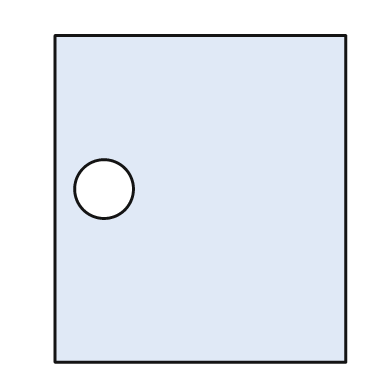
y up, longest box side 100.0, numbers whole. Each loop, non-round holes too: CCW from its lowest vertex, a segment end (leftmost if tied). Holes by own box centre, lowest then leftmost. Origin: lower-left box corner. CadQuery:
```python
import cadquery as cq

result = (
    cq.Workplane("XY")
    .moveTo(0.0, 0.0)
    .lineTo(89.0, 0.0)
    .lineTo(89.0, 100.0)
    .lineTo(0.0, 100.0)
    .close()
    .moveTo(15.0, 53.0)
    .circle(9.0)
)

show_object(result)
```